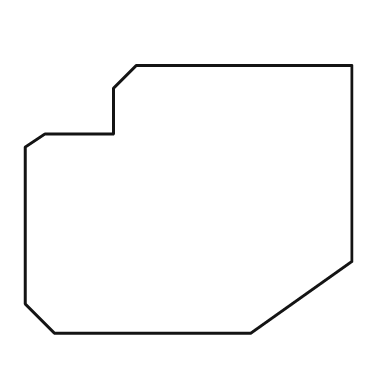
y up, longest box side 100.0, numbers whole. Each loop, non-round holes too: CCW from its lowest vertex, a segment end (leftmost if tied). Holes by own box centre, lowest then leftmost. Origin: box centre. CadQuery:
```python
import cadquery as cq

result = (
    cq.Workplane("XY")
    .moveTo(-41.0, -41.0)
    .lineTo(19.0, -41.0)
    .lineTo(50.0, -19.0)
    .lineTo(50.0, 41.0)
    .lineTo(-16.0, 41.0)
    .lineTo(-23.0, 34.0)
    .lineTo(-23.0, 20.0)
    .lineTo(-44.0, 20.0)
    .lineTo(-50.0, 16.0)
    .lineTo(-50.0, -32.0)
    .close()
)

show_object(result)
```